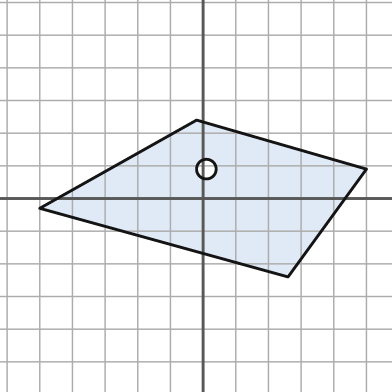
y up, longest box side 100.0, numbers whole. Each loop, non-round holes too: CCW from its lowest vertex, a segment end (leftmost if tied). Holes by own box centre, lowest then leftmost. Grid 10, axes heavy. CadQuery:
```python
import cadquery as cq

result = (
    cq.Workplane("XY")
    .moveTo(26.0, -24.0)
    .lineTo(50.0, 9.0)
    .lineTo(-2.0, 24.0)
    .lineTo(-50.0, -3.0)
    .close()
    .moveTo(1.0, 9.0)
    .circle(3.0)
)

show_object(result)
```